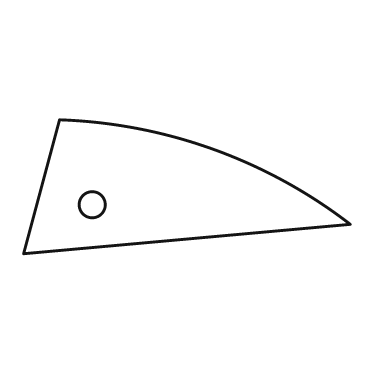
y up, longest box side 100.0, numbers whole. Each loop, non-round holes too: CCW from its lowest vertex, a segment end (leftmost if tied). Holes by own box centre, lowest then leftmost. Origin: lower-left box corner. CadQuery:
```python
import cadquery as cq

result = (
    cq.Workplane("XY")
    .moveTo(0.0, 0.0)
    .lineTo(100.0, 9.0)
    .threePointArc((58.0, 32.0), (11.0, 41.0))
    .close()
    .moveTo(21.0, 15.0)
    .circle(4.0)
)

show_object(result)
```